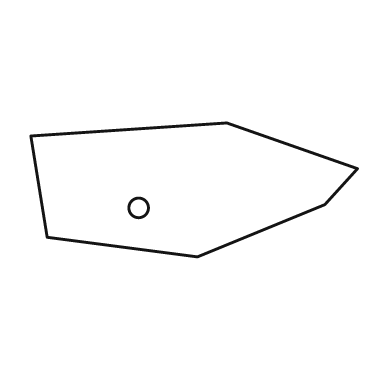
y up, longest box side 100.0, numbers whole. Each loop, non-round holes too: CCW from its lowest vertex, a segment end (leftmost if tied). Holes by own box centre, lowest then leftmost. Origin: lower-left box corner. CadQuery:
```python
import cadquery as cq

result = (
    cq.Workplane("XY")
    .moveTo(51.0, 0.0)
    .lineTo(90.0, 16.0)
    .lineTo(100.0, 27.0)
    .lineTo(60.0, 41.0)
    .lineTo(0.0, 37.0)
    .lineTo(5.0, 6.0)
    .close()
    .moveTo(33.0, 15.0)
    .circle(3.0)
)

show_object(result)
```